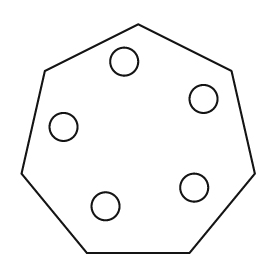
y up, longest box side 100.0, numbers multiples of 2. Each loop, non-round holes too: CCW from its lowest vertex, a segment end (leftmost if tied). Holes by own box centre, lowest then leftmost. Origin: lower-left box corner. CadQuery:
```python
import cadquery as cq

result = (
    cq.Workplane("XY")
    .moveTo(28.0, 0.0)
    .lineTo(72.0, 0.0)
    .lineTo(100.0, 34.0)
    .lineTo(90.0, 78.0)
    .lineTo(50.0, 98.0)
    .lineTo(10.0, 78.0)
    .lineTo(0.0, 34.0)
    .close()
    .moveTo(36.0, 20.0)
    .circle(6.0)
    .moveTo(74.0, 28.0)
    .circle(6.0)
    .moveTo(18.0, 54.0)
    .circle(6.0)
    .moveTo(78.0, 66.0)
    .circle(6.0)
    .moveTo(44.0, 82.0)
    .circle(6.0)
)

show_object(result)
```